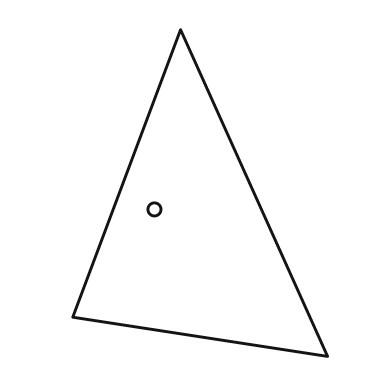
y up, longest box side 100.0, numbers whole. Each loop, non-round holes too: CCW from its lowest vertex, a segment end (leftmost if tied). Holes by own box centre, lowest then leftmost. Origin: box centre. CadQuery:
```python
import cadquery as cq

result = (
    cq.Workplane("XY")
    .moveTo(39.0, -50.0)
    .lineTo(-6.0, 50.0)
    .lineTo(-39.0, -38.0)
    .close()
    .moveTo(-14.0, -5.0)
    .circle(2.0)
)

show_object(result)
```